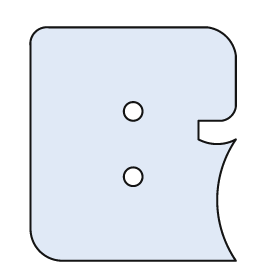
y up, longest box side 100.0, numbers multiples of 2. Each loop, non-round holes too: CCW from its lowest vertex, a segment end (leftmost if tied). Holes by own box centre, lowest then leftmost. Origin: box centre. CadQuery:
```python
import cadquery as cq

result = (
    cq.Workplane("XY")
    .moveTo(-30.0, -50.0)
    .lineTo(44.0, -50.0)
    .threePointArc((36.0, -24.0), (44.0, 2.0))
    .threePointArc((36.0, 0.0), (28.0, 2.0))
    .lineTo(28.0, 10.0)
    .lineTo(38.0, 10.0)
    .threePointArc((42.0, 12.0), (44.0, 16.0))
    .lineTo(44.0, 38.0)
    .threePointArc((40.0, 46.0), (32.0, 50.0))
    .lineTo(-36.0, 50.0)
    .threePointArc((-42.0, 48.0), (-44.0, 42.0))
    .lineTo(-44.0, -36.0)
    .threePointArc((-40.0, -46.0), (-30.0, -50.0))
    .close()
    .moveTo(0.0, -14.0)
    .circle(4.0)
    .moveTo(0.0, 14.0)
    .circle(4.0)
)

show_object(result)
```